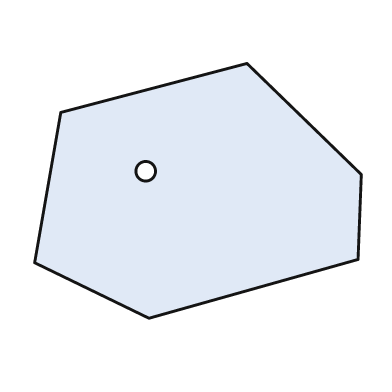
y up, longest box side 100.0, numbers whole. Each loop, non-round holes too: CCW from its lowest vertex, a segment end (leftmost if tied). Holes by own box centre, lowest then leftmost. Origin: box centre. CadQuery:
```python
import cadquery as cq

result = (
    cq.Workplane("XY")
    .moveTo(-15.0, -39.0)
    .lineTo(49.0, -21.0)
    .lineTo(50.0, 5.0)
    .lineTo(15.0, 39.0)
    .lineTo(-42.0, 24.0)
    .lineTo(-50.0, -22.0)
    .close()
    .moveTo(-16.0, 6.0)
    .circle(3.0)
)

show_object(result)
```